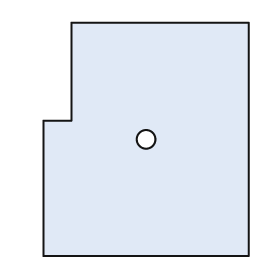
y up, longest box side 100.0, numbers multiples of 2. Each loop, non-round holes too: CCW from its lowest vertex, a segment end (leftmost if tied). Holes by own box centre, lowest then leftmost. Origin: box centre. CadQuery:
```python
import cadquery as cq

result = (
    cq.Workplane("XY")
    .moveTo(-44.0, -50.0)
    .lineTo(44.0, -50.0)
    .lineTo(44.0, 50.0)
    .lineTo(-32.0, 50.0)
    .lineTo(-32.0, 8.0)
    .lineTo(-44.0, 8.0)
    .close()
    .moveTo(0.0, 0.0)
    .circle(4.0)
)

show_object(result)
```